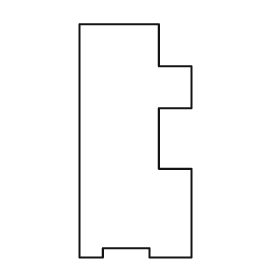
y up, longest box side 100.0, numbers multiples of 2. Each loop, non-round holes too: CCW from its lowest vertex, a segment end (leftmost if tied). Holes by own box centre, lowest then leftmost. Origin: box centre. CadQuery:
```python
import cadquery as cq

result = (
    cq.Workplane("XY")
    .moveTo(-24.0, -50.0)
    .lineTo(-14.0, -50.0)
    .lineTo(-14.0, -46.0)
    .lineTo(6.0, -46.0)
    .lineTo(6.0, -50.0)
    .lineTo(24.0, -50.0)
    .lineTo(24.0, -12.0)
    .lineTo(10.0, -12.0)
    .lineTo(10.0, 14.0)
    .lineTo(24.0, 14.0)
    .lineTo(24.0, 32.0)
    .lineTo(10.0, 32.0)
    .lineTo(10.0, 50.0)
    .lineTo(-24.0, 50.0)
    .close()
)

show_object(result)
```